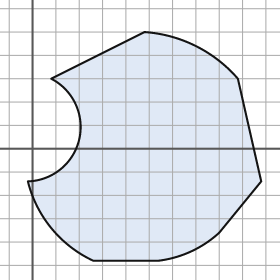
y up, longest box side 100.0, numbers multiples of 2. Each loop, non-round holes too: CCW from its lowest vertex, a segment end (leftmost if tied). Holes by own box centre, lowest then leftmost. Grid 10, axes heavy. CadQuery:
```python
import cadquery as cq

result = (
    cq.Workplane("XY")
    .moveTo(26.0, -48.0)
    .lineTo(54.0, -48.0)
    .threePointArc((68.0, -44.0), (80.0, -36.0))
    .lineTo(98.0, -14.0)
    .lineTo(88.0, 30.0)
    .threePointArc((70.0, 44.0), (48.0, 50.0))
    .lineTo(8.0, 30.0)
    .threePointArc((20.0, 4.0), (-2.0, -14.0))
    .threePointArc((8.0, -34.0), (26.0, -48.0))
    .close()
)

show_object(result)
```